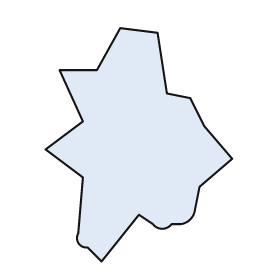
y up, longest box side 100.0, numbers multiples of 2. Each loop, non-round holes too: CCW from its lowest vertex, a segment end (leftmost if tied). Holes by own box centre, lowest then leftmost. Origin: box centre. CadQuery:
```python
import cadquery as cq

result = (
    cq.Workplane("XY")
    .moveTo(-16.0, -50.0)
    .lineTo(0.0, -30.0)
    .lineTo(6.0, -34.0)
    .threePointArc((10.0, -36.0), (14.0, -34.0))
    .lineTo(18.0, -34.0)
    .threePointArc((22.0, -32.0), (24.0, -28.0))
    .lineTo(26.0, -18.0)
    .lineTo(40.0, -6.0)
    .lineTo(28.0, 8.0)
    .lineTo(22.0, 20.0)
    .lineTo(12.0, 22.0)
    .lineTo(8.0, 48.0)
    .lineTo(-8.0, 50.0)
    .lineTo(-18.0, 32.0)
    .lineTo(-34.0, 32.0)
    .lineTo(-24.0, 10.0)
    .lineTo(-40.0, -2.0)
    .lineTo(-24.0, -14.0)
    .lineTo(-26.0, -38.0)
    .threePointArc((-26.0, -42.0), (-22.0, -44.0))
    .close()
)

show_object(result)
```